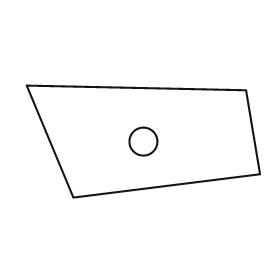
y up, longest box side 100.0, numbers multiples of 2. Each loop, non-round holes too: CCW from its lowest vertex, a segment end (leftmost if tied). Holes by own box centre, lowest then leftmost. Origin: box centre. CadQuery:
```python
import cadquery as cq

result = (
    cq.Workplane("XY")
    .moveTo(-30.0, -24.0)
    .lineTo(50.0, -14.0)
    .lineTo(44.0, 22.0)
    .lineTo(-50.0, 24.0)
    .close()
    .moveTo(0.0, 0.0)
    .circle(6.0)
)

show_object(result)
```